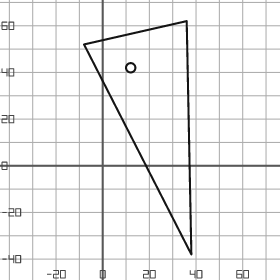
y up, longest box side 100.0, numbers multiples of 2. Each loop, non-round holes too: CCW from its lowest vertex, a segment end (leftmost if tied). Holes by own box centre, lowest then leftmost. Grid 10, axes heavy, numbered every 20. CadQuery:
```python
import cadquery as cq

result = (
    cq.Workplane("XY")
    .moveTo(38.0, -38.0)
    .lineTo(36.0, 62.0)
    .lineTo(-8.0, 52.0)
    .close()
    .moveTo(12.0, 42.0)
    .circle(2.0)
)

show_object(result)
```